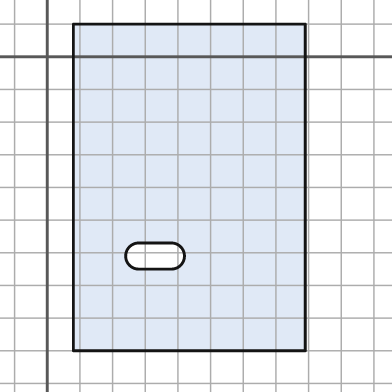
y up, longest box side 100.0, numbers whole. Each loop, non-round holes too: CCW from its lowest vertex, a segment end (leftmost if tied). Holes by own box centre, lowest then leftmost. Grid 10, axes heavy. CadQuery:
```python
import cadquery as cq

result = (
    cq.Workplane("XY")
    .moveTo(8.0, -90.0)
    .lineTo(79.0, -90.0)
    .lineTo(79.0, 10.0)
    .lineTo(8.0, 10.0)
    .close()
    .moveTo(28.0, -65.0)
    .lineTo(38.0, -65.0)
    .threePointArc((42.0, -61.0), (38.0, -57.0))
    .lineTo(28.0, -57.0)
    .threePointArc((24.0, -61.0), (28.0, -65.0))
    .close()
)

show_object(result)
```